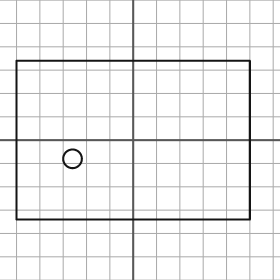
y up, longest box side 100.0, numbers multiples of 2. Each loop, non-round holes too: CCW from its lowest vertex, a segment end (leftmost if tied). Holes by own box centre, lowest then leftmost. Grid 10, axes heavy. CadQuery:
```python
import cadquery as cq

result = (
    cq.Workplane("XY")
    .moveTo(-50.0, -34.0)
    .lineTo(50.0, -34.0)
    .lineTo(50.0, 34.0)
    .lineTo(-50.0, 34.0)
    .close()
    .moveTo(-26.0, -8.0)
    .circle(4.0)
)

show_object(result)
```